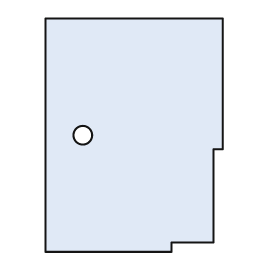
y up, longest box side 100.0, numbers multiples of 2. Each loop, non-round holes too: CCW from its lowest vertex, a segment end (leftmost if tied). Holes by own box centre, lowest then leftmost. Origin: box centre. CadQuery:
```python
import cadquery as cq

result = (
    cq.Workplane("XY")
    .moveTo(-38.0, -50.0)
    .lineTo(16.0, -50.0)
    .lineTo(16.0, -46.0)
    .lineTo(34.0, -46.0)
    .lineTo(34.0, -6.0)
    .lineTo(38.0, -6.0)
    .lineTo(38.0, 50.0)
    .lineTo(-38.0, 50.0)
    .close()
    .moveTo(-22.0, 0.0)
    .circle(4.0)
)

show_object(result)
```